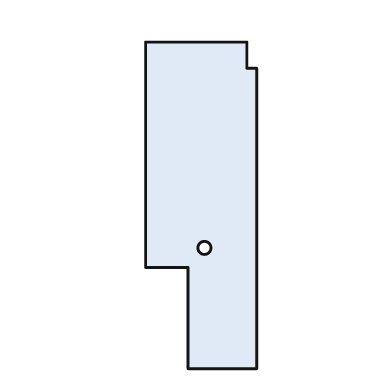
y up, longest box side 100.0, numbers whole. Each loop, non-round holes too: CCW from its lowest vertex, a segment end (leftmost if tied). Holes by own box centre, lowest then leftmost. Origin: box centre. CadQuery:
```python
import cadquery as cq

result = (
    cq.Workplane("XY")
    .moveTo(-4.0, -50.0)
    .lineTo(17.0, -50.0)
    .lineTo(17.0, 42.0)
    .lineTo(14.0, 42.0)
    .lineTo(14.0, 50.0)
    .lineTo(-17.0, 50.0)
    .lineTo(-17.0, -19.0)
    .lineTo(-4.0, -19.0)
    .close()
    .moveTo(1.0, -13.0)
    .circle(2.0)
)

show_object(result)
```